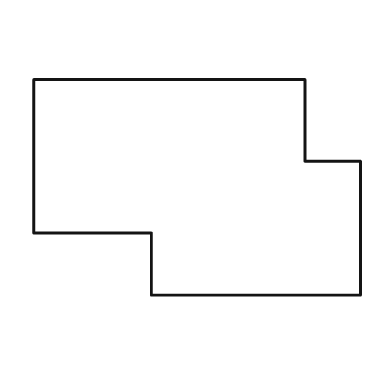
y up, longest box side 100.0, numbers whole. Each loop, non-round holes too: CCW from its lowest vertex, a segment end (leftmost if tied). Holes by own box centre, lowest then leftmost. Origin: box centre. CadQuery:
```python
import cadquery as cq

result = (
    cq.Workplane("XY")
    .moveTo(-14.0, -33.0)
    .lineTo(50.0, -33.0)
    .lineTo(50.0, 8.0)
    .lineTo(33.0, 8.0)
    .lineTo(33.0, 33.0)
    .lineTo(-50.0, 33.0)
    .lineTo(-50.0, -14.0)
    .lineTo(-14.0, -14.0)
    .close()
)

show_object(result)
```